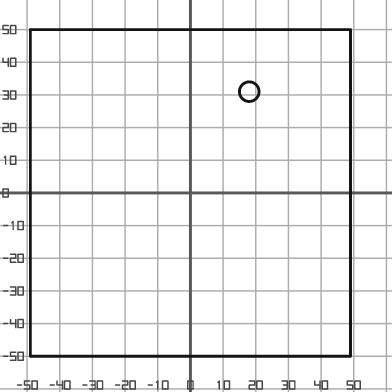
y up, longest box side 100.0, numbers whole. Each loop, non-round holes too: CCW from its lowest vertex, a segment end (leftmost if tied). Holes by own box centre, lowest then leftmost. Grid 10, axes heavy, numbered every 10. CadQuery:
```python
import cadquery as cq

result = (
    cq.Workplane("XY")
    .moveTo(-49.0, -50.0)
    .lineTo(49.0, -50.0)
    .lineTo(49.0, 50.0)
    .lineTo(-49.0, 50.0)
    .close()
    .moveTo(18.0, 31.0)
    .circle(3.0)
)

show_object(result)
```